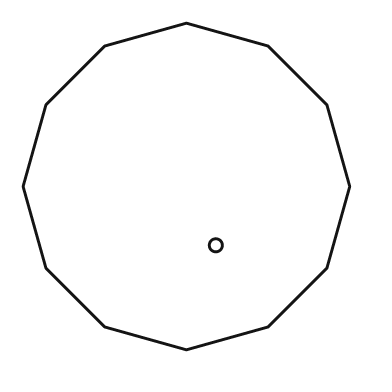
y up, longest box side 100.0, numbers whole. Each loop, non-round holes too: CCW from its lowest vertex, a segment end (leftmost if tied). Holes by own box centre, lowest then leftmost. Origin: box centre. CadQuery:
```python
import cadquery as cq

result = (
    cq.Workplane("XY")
    .moveTo(0.0, -50.0)
    .lineTo(25.0, -43.0)
    .lineTo(43.0, -25.0)
    .lineTo(50.0, 0.0)
    .lineTo(43.0, 25.0)
    .lineTo(25.0, 43.0)
    .lineTo(0.0, 50.0)
    .lineTo(-25.0, 43.0)
    .lineTo(-43.0, 25.0)
    .lineTo(-50.0, 0.0)
    .lineTo(-43.0, -25.0)
    .lineTo(-25.0, -43.0)
    .close()
    .moveTo(9.0, -18.0)
    .circle(2.0)
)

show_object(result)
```